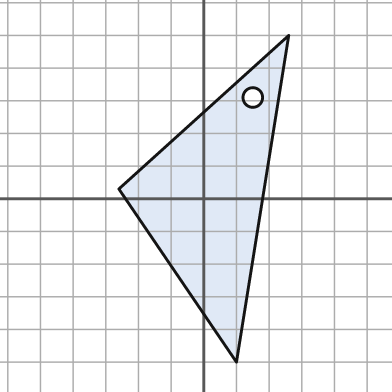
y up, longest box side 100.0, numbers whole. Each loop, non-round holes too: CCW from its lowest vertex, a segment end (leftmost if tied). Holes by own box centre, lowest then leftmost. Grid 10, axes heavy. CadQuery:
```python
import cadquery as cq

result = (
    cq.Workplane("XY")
    .moveTo(10.0, -50.0)
    .lineTo(26.0, 50.0)
    .lineTo(-26.0, 3.0)
    .close()
    .moveTo(15.0, 31.0)
    .circle(3.0)
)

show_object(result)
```